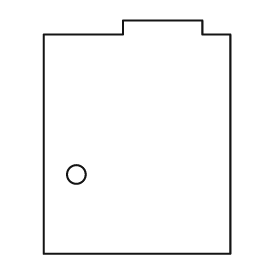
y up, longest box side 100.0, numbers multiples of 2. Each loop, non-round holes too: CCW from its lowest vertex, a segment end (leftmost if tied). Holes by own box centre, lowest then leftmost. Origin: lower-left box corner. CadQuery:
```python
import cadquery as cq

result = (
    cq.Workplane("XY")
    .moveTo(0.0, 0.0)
    .lineTo(80.0, 0.0)
    .lineTo(80.0, 94.0)
    .lineTo(68.0, 94.0)
    .lineTo(68.0, 100.0)
    .lineTo(34.0, 100.0)
    .lineTo(34.0, 94.0)
    .lineTo(0.0, 94.0)
    .close()
    .moveTo(14.0, 34.0)
    .circle(4.0)
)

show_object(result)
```